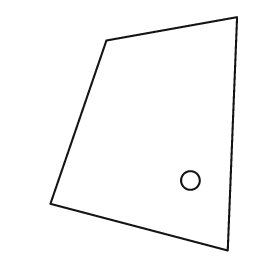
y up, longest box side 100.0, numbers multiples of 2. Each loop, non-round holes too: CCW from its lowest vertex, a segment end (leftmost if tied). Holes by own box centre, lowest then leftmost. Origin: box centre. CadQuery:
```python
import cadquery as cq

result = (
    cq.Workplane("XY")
    .moveTo(36.0, -50.0)
    .lineTo(40.0, 50.0)
    .lineTo(-16.0, 40.0)
    .lineTo(-40.0, -30.0)
    .close()
    .moveTo(20.0, -20.0)
    .circle(4.0)
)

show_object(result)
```